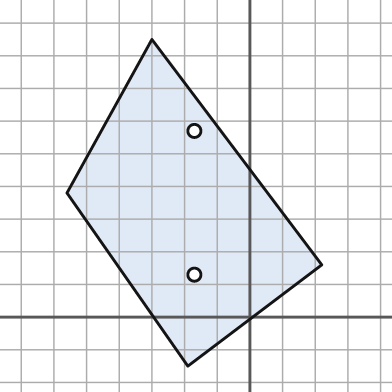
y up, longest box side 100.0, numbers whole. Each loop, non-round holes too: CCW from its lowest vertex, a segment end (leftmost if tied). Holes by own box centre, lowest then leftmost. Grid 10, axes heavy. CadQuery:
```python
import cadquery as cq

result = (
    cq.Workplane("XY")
    .moveTo(-19.0, -15.0)
    .lineTo(22.0, 16.0)
    .lineTo(-30.0, 85.0)
    .lineTo(-56.0, 38.0)
    .close()
    .moveTo(-17.0, 13.0)
    .circle(2.0)
    .moveTo(-17.0, 57.0)
    .circle(2.0)
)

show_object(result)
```